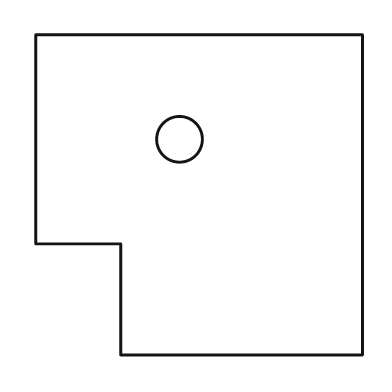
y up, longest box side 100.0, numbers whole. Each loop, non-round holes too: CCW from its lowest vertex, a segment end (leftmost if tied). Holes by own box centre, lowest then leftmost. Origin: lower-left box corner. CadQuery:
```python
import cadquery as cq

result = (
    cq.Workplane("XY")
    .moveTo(26.0, 0.0)
    .lineTo(100.0, 0.0)
    .lineTo(100.0, 98.0)
    .lineTo(0.0, 98.0)
    .lineTo(0.0, 34.0)
    .lineTo(26.0, 34.0)
    .close()
    .moveTo(44.0, 66.0)
    .circle(7.0)
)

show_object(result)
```